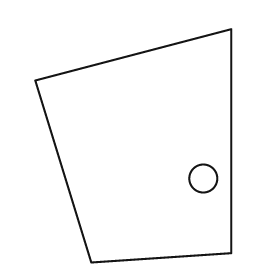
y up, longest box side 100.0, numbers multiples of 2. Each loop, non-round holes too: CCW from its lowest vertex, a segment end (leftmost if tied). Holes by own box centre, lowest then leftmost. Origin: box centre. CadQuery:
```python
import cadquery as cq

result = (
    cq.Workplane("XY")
    .moveTo(-18.0, -50.0)
    .lineTo(42.0, -46.0)
    .lineTo(42.0, 50.0)
    .lineTo(-42.0, 28.0)
    .close()
    .moveTo(30.0, -14.0)
    .circle(6.0)
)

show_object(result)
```